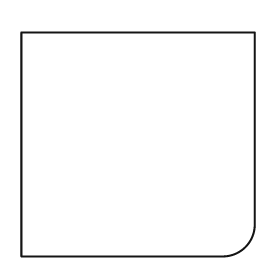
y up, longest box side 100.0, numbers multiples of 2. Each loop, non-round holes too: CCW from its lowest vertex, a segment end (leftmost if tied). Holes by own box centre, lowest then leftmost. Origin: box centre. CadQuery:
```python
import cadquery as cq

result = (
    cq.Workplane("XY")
    .moveTo(-50.0, -48.0)
    .lineTo(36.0, -48.0)
    .threePointArc((46.0, -44.0), (50.0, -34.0))
    .lineTo(50.0, 48.0)
    .lineTo(-50.0, 48.0)
    .close()
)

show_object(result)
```